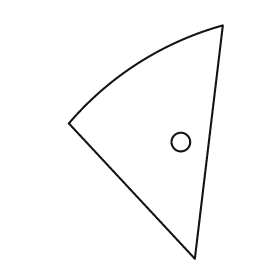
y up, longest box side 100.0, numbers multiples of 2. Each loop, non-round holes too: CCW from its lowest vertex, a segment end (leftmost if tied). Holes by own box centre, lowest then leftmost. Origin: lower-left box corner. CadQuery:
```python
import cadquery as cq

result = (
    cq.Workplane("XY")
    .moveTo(54.0, 0.0)
    .lineTo(66.0, 100.0)
    .threePointArc((30.0, 84.0), (0.0, 58.0))
    .close()
    .moveTo(48.0, 50.0)
    .circle(4.0)
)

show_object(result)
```